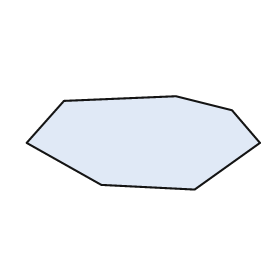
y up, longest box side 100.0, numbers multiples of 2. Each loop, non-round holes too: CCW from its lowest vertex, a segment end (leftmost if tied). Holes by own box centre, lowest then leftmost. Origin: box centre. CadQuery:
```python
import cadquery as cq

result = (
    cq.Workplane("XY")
    .moveTo(22.0, -20.0)
    .lineTo(50.0, 0.0)
    .lineTo(38.0, 14.0)
    .lineTo(14.0, 20.0)
    .lineTo(-34.0, 18.0)
    .lineTo(-50.0, 0.0)
    .lineTo(-18.0, -18.0)
    .close()
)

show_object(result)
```